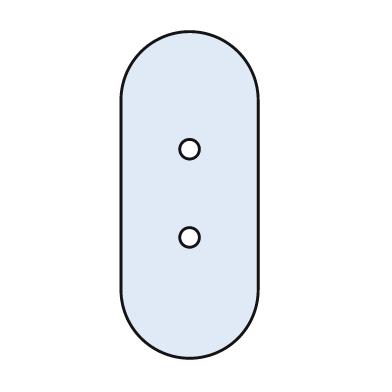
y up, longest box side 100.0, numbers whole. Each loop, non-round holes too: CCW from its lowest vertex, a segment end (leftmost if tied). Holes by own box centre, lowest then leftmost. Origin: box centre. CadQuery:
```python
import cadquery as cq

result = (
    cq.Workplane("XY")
    .moveTo(-21.0, -29.0)
    .threePointArc((0.0, -50.0), (21.0, -29.0))
    .lineTo(21.0, 29.0)
    .threePointArc((0.0, 50.0), (-21.0, 29.0))
    .close()
    .moveTo(0.0, -13.0)
    .circle(3.0)
    .moveTo(0.0, 14.0)
    .circle(3.0)
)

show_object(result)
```